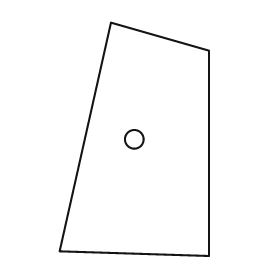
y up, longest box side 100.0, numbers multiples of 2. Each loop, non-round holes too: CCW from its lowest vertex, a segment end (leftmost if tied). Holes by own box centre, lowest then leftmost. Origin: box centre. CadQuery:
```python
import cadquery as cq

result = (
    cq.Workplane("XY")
    .moveTo(32.0, -50.0)
    .lineTo(32.0, 38.0)
    .lineTo(-10.0, 50.0)
    .lineTo(-32.0, -48.0)
    .close()
    .moveTo(0.0, 0.0)
    .circle(4.0)
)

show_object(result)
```